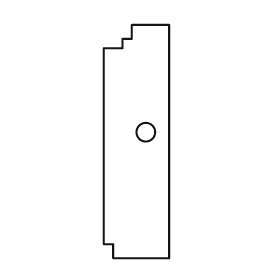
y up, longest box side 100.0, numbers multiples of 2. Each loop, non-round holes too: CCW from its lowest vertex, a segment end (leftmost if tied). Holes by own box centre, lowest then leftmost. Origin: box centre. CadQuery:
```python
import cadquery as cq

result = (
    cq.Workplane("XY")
    .moveTo(-10.0, -50.0)
    .lineTo(14.0, -50.0)
    .lineTo(14.0, 50.0)
    .lineTo(-2.0, 50.0)
    .lineTo(-2.0, 44.0)
    .lineTo(-6.0, 44.0)
    .lineTo(-6.0, 40.0)
    .lineTo(-14.0, 40.0)
    .lineTo(-14.0, -44.0)
    .lineTo(-10.0, -44.0)
    .close()
    .moveTo(4.0, 4.0)
    .circle(4.0)
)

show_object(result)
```